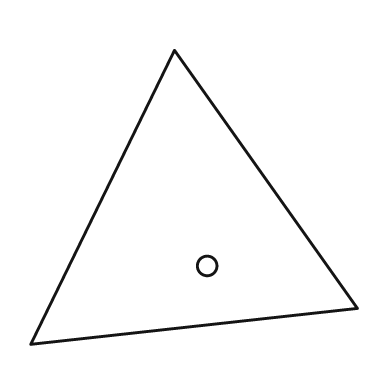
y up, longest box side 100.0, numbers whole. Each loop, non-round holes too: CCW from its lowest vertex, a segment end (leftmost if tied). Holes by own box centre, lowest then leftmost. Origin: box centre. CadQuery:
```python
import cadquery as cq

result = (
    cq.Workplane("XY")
    .moveTo(-50.0, -45.0)
    .lineTo(50.0, -34.0)
    .lineTo(-6.0, 45.0)
    .close()
    .moveTo(4.0, -21.0)
    .circle(3.0)
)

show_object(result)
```